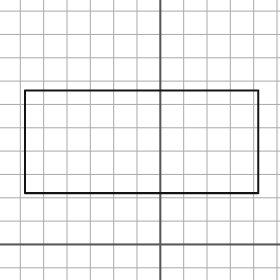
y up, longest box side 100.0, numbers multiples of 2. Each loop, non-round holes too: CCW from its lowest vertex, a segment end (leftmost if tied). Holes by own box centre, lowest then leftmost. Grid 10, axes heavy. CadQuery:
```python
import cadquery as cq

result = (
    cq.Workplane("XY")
    .moveTo(-58.0, 22.0)
    .lineTo(42.0, 22.0)
    .lineTo(42.0, 66.0)
    .lineTo(-58.0, 66.0)
    .close()
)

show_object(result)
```